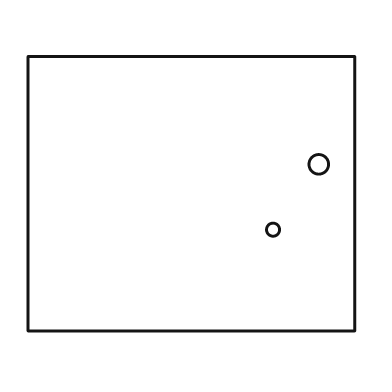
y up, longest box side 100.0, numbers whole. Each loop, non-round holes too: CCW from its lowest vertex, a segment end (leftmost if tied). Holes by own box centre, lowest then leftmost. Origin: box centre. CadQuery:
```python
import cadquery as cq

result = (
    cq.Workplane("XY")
    .moveTo(-50.0, -42.0)
    .lineTo(50.0, -42.0)
    .lineTo(50.0, 42.0)
    .lineTo(-50.0, 42.0)
    .close()
    .moveTo(25.0, -11.0)
    .circle(2.0)
    .moveTo(39.0, 9.0)
    .circle(3.0)
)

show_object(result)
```